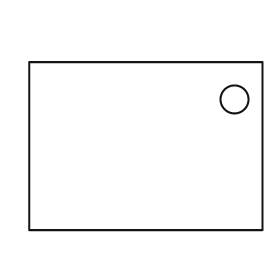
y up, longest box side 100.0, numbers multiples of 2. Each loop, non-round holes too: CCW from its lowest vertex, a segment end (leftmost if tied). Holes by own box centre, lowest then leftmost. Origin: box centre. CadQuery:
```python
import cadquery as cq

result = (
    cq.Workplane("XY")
    .moveTo(-50.0, -36.0)
    .lineTo(50.0, -36.0)
    .lineTo(50.0, 36.0)
    .lineTo(-50.0, 36.0)
    .close()
    .moveTo(38.0, 20.0)
    .circle(6.0)
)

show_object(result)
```